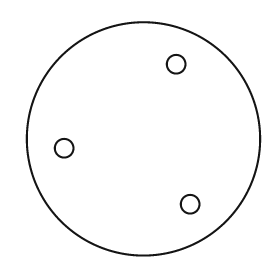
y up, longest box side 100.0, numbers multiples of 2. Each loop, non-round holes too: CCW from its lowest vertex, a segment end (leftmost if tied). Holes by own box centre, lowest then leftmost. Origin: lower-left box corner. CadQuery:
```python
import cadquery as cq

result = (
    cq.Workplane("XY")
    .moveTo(50.0, 50.0)
    .circle(50.0)
    .moveTo(70.0, 22.0)
    .circle(4.0)
    .moveTo(16.0, 46.0)
    .circle(4.0)
    .moveTo(64.0, 82.0)
    .circle(4.0)
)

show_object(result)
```